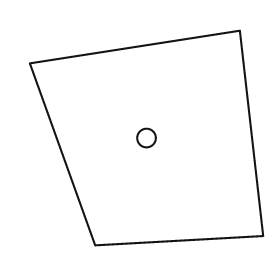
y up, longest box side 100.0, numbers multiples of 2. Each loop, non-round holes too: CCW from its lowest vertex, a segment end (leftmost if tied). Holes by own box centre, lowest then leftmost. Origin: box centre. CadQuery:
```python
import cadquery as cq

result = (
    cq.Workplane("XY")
    .moveTo(-22.0, -46.0)
    .lineTo(50.0, -42.0)
    .lineTo(40.0, 46.0)
    .lineTo(-50.0, 32.0)
    .close()
    .moveTo(0.0, 0.0)
    .circle(4.0)
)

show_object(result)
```